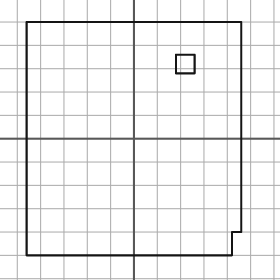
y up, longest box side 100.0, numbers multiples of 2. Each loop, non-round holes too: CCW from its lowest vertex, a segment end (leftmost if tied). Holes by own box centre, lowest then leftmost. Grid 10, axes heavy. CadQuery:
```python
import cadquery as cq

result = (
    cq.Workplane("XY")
    .moveTo(-46.0, -50.0)
    .lineTo(42.0, -50.0)
    .lineTo(42.0, -40.0)
    .lineTo(46.0, -40.0)
    .lineTo(46.0, 50.0)
    .lineTo(-46.0, 50.0)
    .close()
    .moveTo(18.0, 28.0)
    .lineTo(26.0, 28.0)
    .lineTo(26.0, 36.0)
    .lineTo(18.0, 36.0)
    .close()
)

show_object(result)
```